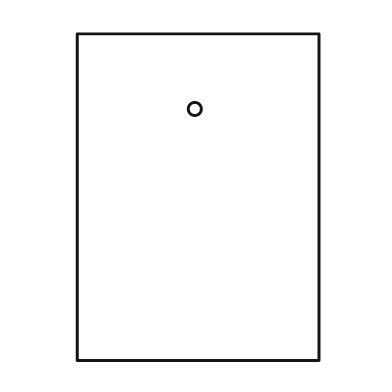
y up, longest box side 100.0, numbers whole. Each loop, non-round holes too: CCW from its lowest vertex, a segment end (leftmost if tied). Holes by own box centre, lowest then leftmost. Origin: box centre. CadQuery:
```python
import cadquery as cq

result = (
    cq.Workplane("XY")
    .moveTo(-37.0, -50.0)
    .lineTo(37.0, -50.0)
    .lineTo(37.0, 50.0)
    .lineTo(-37.0, 50.0)
    .close()
    .moveTo(-1.0, 27.0)
    .circle(2.0)
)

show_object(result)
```